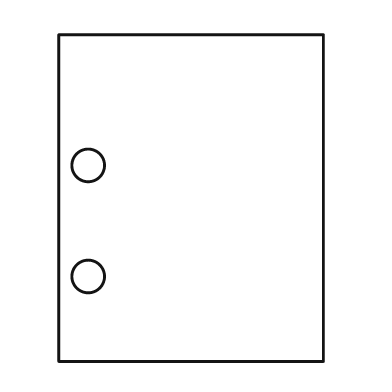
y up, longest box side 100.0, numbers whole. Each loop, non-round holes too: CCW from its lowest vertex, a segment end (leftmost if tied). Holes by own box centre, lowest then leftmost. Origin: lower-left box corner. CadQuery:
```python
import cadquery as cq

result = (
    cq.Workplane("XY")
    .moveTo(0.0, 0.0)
    .lineTo(81.0, 0.0)
    .lineTo(81.0, 100.0)
    .lineTo(0.0, 100.0)
    .close()
    .moveTo(9.0, 26.0)
    .circle(5.0)
    .moveTo(9.0, 60.0)
    .circle(5.0)
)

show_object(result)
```